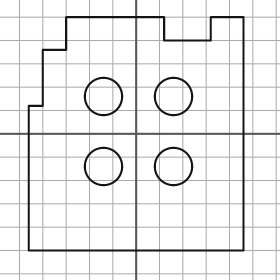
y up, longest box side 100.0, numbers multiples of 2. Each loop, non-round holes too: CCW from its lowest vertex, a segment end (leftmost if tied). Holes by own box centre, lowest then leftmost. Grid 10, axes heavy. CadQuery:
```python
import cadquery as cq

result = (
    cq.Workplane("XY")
    .moveTo(-46.0, -50.0)
    .lineTo(46.0, -50.0)
    .lineTo(46.0, 50.0)
    .lineTo(32.0, 50.0)
    .lineTo(32.0, 40.0)
    .lineTo(12.0, 40.0)
    .lineTo(12.0, 50.0)
    .lineTo(-30.0, 50.0)
    .lineTo(-30.0, 36.0)
    .lineTo(-40.0, 36.0)
    .lineTo(-40.0, 12.0)
    .lineTo(-46.0, 12.0)
    .close()
    .moveTo(-14.0, -14.0)
    .circle(8.0)
    .moveTo(16.0, -14.0)
    .circle(8.0)
    .moveTo(-14.0, 16.0)
    .circle(8.0)
    .moveTo(16.0, 16.0)
    .circle(8.0)
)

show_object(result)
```